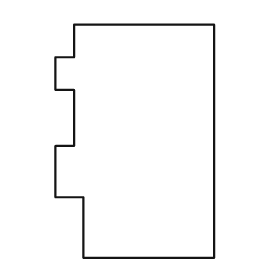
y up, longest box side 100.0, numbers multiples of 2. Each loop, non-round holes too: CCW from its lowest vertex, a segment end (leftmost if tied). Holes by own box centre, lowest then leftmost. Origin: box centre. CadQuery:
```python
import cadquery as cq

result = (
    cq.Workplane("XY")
    .moveTo(-22.0, -50.0)
    .lineTo(34.0, -50.0)
    .lineTo(34.0, 50.0)
    .lineTo(-26.0, 50.0)
    .lineTo(-26.0, 36.0)
    .lineTo(-34.0, 36.0)
    .lineTo(-34.0, 22.0)
    .lineTo(-26.0, 22.0)
    .lineTo(-26.0, -2.0)
    .lineTo(-34.0, -2.0)
    .lineTo(-34.0, -24.0)
    .lineTo(-22.0, -24.0)
    .close()
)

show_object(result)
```